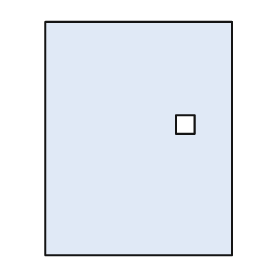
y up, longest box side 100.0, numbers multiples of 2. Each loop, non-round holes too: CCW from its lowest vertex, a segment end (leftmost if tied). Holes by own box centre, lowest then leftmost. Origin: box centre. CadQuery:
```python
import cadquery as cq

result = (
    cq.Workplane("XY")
    .moveTo(-40.0, -50.0)
    .lineTo(40.0, -50.0)
    .lineTo(40.0, 50.0)
    .lineTo(-40.0, 50.0)
    .close()
    .moveTo(16.0, 2.0)
    .lineTo(24.0, 2.0)
    .lineTo(24.0, 10.0)
    .lineTo(16.0, 10.0)
    .close()
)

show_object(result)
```